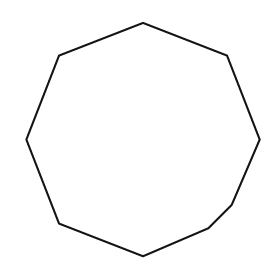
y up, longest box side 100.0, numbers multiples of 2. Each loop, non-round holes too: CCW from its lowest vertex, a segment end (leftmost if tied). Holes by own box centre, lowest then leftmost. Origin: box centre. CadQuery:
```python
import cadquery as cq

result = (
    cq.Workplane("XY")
    .moveTo(0.0, -50.0)
    .lineTo(28.0, -38.0)
    .lineTo(38.0, -28.0)
    .lineTo(50.0, 0.0)
    .lineTo(36.0, 36.0)
    .lineTo(0.0, 50.0)
    .lineTo(-36.0, 36.0)
    .lineTo(-50.0, 0.0)
    .lineTo(-36.0, -36.0)
    .close()
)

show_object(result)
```